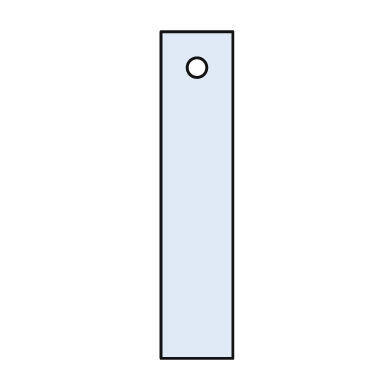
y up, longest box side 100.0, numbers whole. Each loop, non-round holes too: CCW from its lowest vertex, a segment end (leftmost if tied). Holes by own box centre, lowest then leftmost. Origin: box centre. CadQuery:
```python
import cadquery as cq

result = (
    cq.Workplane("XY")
    .moveTo(-11.0, -50.0)
    .lineTo(11.0, -50.0)
    .lineTo(11.0, 50.0)
    .lineTo(-11.0, 50.0)
    .close()
    .moveTo(0.0, 39.0)
    .circle(3.0)
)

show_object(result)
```